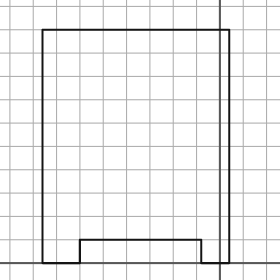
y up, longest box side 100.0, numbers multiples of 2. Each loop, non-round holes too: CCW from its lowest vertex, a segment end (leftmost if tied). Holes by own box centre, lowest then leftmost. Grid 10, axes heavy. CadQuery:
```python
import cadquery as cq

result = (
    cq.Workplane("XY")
    .moveTo(-76.0, 0.0)
    .lineTo(-60.0, 0.0)
    .lineTo(-60.0, 10.0)
    .lineTo(-8.0, 10.0)
    .lineTo(-8.0, 0.0)
    .lineTo(4.0, 0.0)
    .lineTo(4.0, 100.0)
    .lineTo(-76.0, 100.0)
    .close()
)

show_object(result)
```